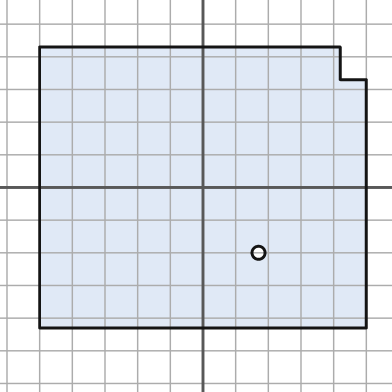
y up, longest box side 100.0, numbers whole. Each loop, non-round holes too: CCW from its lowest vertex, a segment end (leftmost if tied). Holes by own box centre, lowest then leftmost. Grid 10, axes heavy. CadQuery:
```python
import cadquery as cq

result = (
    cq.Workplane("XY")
    .moveTo(-50.0, -43.0)
    .lineTo(50.0, -43.0)
    .lineTo(50.0, 33.0)
    .lineTo(42.0, 33.0)
    .lineTo(42.0, 43.0)
    .lineTo(-50.0, 43.0)
    .close()
    .moveTo(17.0, -20.0)
    .circle(2.0)
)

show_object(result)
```